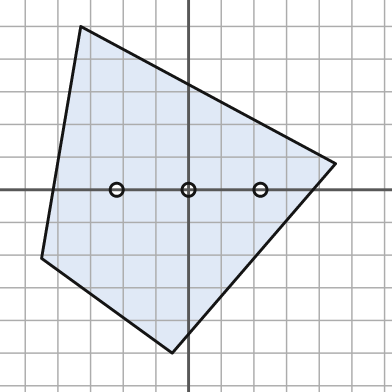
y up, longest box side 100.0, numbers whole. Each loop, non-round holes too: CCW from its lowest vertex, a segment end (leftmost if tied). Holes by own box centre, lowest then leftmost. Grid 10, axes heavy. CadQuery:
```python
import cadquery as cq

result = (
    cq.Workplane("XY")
    .moveTo(-5.0, -50.0)
    .lineTo(45.0, 8.0)
    .lineTo(-33.0, 50.0)
    .lineTo(-45.0, -21.0)
    .close()
    .moveTo(-22.0, 0.0)
    .circle(2.0)
    .moveTo(0.0, 0.0)
    .circle(2.0)
    .moveTo(22.0, 0.0)
    .circle(2.0)
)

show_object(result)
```